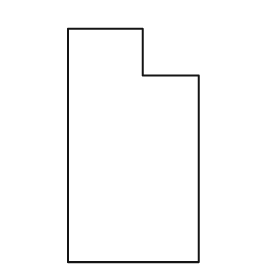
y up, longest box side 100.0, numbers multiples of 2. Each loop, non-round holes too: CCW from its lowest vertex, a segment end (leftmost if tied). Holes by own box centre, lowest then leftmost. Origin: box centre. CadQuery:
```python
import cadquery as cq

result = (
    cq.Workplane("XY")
    .moveTo(-28.0, -50.0)
    .lineTo(28.0, -50.0)
    .lineTo(28.0, 30.0)
    .lineTo(4.0, 30.0)
    .lineTo(4.0, 50.0)
    .lineTo(-28.0, 50.0)
    .close()
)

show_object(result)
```